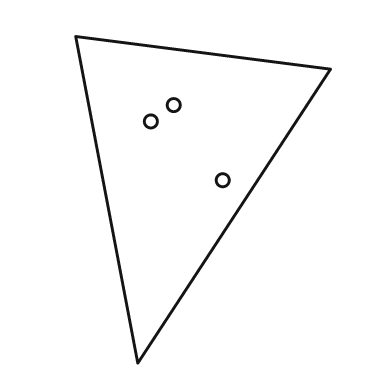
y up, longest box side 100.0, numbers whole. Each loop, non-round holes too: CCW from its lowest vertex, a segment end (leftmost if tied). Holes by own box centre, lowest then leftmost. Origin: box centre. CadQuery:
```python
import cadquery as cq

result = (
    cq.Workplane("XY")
    .moveTo(-20.0, -50.0)
    .lineTo(39.0, 40.0)
    .lineTo(-39.0, 50.0)
    .close()
    .moveTo(6.0, 6.0)
    .circle(2.0)
    .moveTo(-16.0, 24.0)
    .circle(2.0)
    .moveTo(-9.0, 29.0)
    .circle(2.0)
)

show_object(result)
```